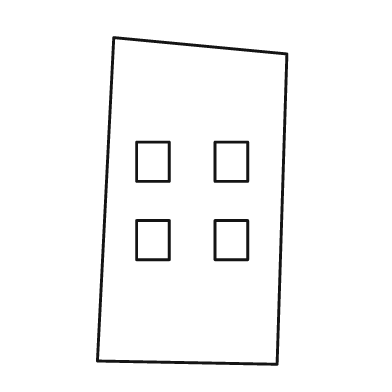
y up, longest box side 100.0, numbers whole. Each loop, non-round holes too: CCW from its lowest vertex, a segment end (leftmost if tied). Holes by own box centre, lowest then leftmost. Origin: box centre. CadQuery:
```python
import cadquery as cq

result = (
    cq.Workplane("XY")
    .moveTo(26.0, -50.0)
    .lineTo(29.0, 45.0)
    .lineTo(-24.0, 50.0)
    .lineTo(-29.0, -49.0)
    .close()
    .moveTo(-17.0, -18.0)
    .lineTo(-7.0, -18.0)
    .lineTo(-7.0, -6.0)
    .lineTo(-17.0, -6.0)
    .close()
    .moveTo(7.0, -18.0)
    .lineTo(17.0, -18.0)
    .lineTo(17.0, -6.0)
    .lineTo(7.0, -6.0)
    .close()
    .moveTo(-17.0, 6.0)
    .lineTo(-7.0, 6.0)
    .lineTo(-7.0, 18.0)
    .lineTo(-17.0, 18.0)
    .close()
    .moveTo(7.0, 6.0)
    .lineTo(17.0, 6.0)
    .lineTo(17.0, 18.0)
    .lineTo(7.0, 18.0)
    .close()
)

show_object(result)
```